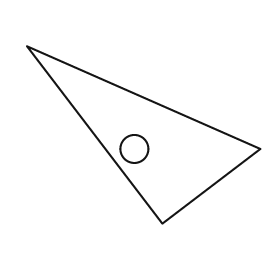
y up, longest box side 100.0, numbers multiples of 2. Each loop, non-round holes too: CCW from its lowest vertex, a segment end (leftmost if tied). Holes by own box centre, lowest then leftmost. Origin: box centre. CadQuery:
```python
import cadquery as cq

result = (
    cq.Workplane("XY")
    .moveTo(8.0, -38.0)
    .lineTo(50.0, -6.0)
    .lineTo(-50.0, 38.0)
    .close()
    .moveTo(-4.0, -6.0)
    .circle(6.0)
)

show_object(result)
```